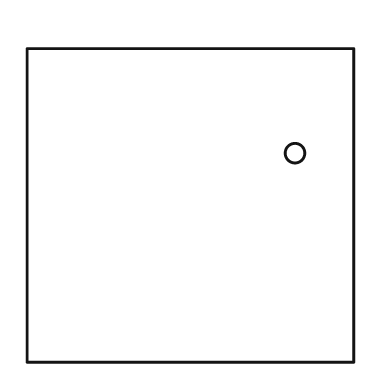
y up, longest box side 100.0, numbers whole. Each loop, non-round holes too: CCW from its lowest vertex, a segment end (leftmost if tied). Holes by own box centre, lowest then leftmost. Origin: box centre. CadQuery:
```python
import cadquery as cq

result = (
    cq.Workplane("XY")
    .moveTo(-50.0, -48.0)
    .lineTo(50.0, -48.0)
    .lineTo(50.0, 48.0)
    .lineTo(-50.0, 48.0)
    .close()
    .moveTo(32.0, 16.0)
    .circle(3.0)
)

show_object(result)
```